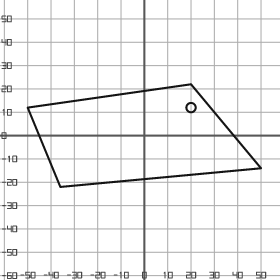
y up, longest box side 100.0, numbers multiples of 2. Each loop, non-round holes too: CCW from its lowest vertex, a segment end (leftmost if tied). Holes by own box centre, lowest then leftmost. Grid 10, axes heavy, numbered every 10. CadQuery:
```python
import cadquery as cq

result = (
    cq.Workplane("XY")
    .moveTo(-36.0, -22.0)
    .lineTo(50.0, -14.0)
    .lineTo(20.0, 22.0)
    .lineTo(-50.0, 12.0)
    .close()
    .moveTo(20.0, 12.0)
    .circle(2.0)
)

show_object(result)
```